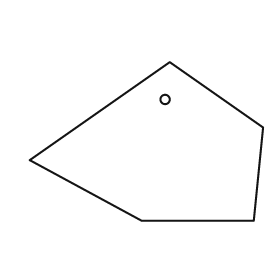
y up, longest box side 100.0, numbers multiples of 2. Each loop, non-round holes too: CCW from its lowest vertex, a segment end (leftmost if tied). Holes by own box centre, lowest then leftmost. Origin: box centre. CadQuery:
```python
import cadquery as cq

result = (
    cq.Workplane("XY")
    .moveTo(-2.0, -34.0)
    .lineTo(46.0, -34.0)
    .lineTo(50.0, 6.0)
    .lineTo(10.0, 34.0)
    .lineTo(-50.0, -8.0)
    .close()
    .moveTo(8.0, 18.0)
    .circle(2.0)
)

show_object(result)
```